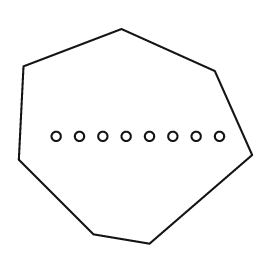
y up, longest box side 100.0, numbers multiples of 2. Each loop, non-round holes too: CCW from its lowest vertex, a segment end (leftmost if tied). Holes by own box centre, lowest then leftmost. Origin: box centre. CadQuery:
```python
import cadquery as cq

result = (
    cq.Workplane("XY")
    .moveTo(6.0, -46.0)
    .lineTo(50.0, -8.0)
    .lineTo(34.0, 28.0)
    .lineTo(-6.0, 46.0)
    .lineTo(-48.0, 30.0)
    .lineTo(-50.0, -10.0)
    .lineTo(-18.0, -42.0)
    .close()
    .moveTo(-34.0, 0.0)
    .circle(2.0)
    .moveTo(-24.0, 0.0)
    .circle(2.0)
    .moveTo(-14.0, 0.0)
    .circle(2.0)
    .moveTo(-4.0, 0.0)
    .circle(2.0)
    .moveTo(6.0, 0.0)
    .circle(2.0)
    .moveTo(16.0, 0.0)
    .circle(2.0)
    .moveTo(26.0, 0.0)
    .circle(2.0)
    .moveTo(36.0, 0.0)
    .circle(2.0)
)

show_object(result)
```